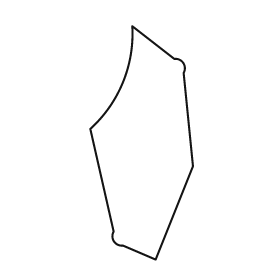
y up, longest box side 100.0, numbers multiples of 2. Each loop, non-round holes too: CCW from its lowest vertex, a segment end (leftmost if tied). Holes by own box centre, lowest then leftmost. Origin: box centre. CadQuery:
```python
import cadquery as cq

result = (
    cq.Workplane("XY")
    .moveTo(6.0, -50.0)
    .lineTo(22.0, -10.0)
    .lineTo(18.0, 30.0)
    .threePointArc((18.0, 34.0), (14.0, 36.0))
    .lineTo(-4.0, 50.0)
    .threePointArc((-8.0, 26.0), (-22.0, 6.0))
    .lineTo(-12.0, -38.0)
    .threePointArc((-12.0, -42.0), (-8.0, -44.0))
    .close()
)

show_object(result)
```